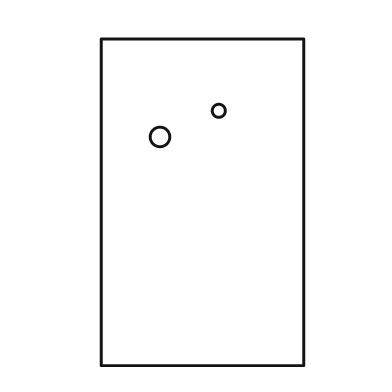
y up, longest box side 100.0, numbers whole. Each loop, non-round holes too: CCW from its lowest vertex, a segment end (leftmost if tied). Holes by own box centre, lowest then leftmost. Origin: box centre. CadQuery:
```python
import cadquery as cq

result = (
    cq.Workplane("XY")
    .moveTo(-31.0, -50.0)
    .lineTo(31.0, -50.0)
    .lineTo(31.0, 50.0)
    .lineTo(-31.0, 50.0)
    .close()
    .moveTo(-13.0, 20.0)
    .circle(3.0)
    .moveTo(5.0, 28.0)
    .circle(2.0)
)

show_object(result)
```